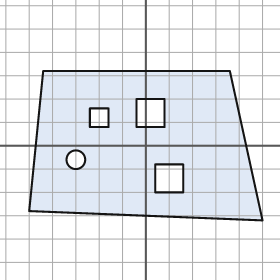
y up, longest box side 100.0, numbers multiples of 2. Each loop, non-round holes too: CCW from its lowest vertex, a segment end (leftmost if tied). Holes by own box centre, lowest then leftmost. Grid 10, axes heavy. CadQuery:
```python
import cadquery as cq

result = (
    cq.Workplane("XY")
    .moveTo(50.0, -32.0)
    .lineTo(36.0, 32.0)
    .lineTo(-44.0, 32.0)
    .lineTo(-50.0, -28.0)
    .close()
    .moveTo(4.0, -20.0)
    .lineTo(16.0, -20.0)
    .lineTo(16.0, -8.0)
    .lineTo(4.0, -8.0)
    .close()
    .moveTo(-30.0, -6.0)
    .circle(4.0)
    .moveTo(-24.0, 8.0)
    .lineTo(-16.0, 8.0)
    .lineTo(-16.0, 16.0)
    .lineTo(-24.0, 16.0)
    .close()
    .moveTo(-4.0, 8.0)
    .lineTo(8.0, 8.0)
    .lineTo(8.0, 20.0)
    .lineTo(-4.0, 20.0)
    .close()
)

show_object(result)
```